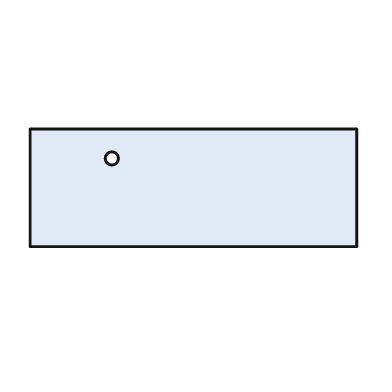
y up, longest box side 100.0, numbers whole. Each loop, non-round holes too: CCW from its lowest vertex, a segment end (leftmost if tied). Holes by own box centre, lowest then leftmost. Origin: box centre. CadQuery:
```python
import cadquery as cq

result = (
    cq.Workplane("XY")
    .moveTo(-50.0, -18.0)
    .lineTo(50.0, -18.0)
    .lineTo(50.0, 18.0)
    .lineTo(-50.0, 18.0)
    .close()
    .moveTo(-25.0, 9.0)
    .circle(2.0)
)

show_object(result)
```